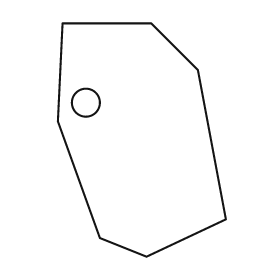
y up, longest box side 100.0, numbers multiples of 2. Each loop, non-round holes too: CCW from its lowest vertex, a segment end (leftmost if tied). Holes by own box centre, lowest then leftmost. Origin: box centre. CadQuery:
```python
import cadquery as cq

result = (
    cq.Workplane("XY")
    .moveTo(2.0, -50.0)
    .lineTo(36.0, -34.0)
    .lineTo(24.0, 30.0)
    .lineTo(4.0, 50.0)
    .lineTo(-34.0, 50.0)
    .lineTo(-36.0, 8.0)
    .lineTo(-18.0, -42.0)
    .close()
    .moveTo(-24.0, 16.0)
    .circle(6.0)
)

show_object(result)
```